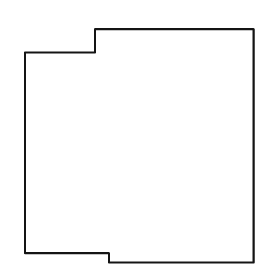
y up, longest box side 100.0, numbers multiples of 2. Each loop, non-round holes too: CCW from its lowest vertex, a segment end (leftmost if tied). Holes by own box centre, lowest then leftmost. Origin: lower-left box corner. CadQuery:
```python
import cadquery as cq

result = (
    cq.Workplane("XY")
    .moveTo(36.0, 0.0)
    .lineTo(98.0, 0.0)
    .lineTo(98.0, 100.0)
    .lineTo(30.0, 100.0)
    .lineTo(30.0, 90.0)
    .lineTo(0.0, 90.0)
    .lineTo(0.0, 4.0)
    .lineTo(36.0, 4.0)
    .close()
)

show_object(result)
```